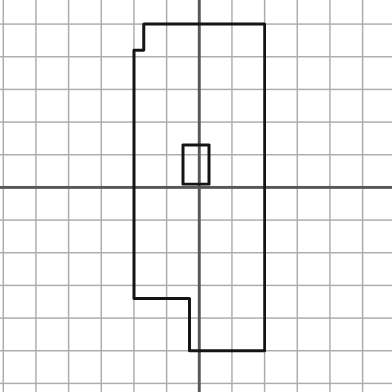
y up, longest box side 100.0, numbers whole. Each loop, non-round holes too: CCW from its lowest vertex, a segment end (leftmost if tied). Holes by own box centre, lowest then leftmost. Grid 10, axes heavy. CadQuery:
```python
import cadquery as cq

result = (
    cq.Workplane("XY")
    .moveTo(-3.0, -50.0)
    .lineTo(20.0, -50.0)
    .lineTo(20.0, 50.0)
    .lineTo(-17.0, 50.0)
    .lineTo(-17.0, 42.0)
    .lineTo(-20.0, 42.0)
    .lineTo(-20.0, -34.0)
    .lineTo(-3.0, -34.0)
    .close()
    .moveTo(-5.0, 1.0)
    .lineTo(3.0, 1.0)
    .lineTo(3.0, 13.0)
    .lineTo(-5.0, 13.0)
    .close()
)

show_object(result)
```